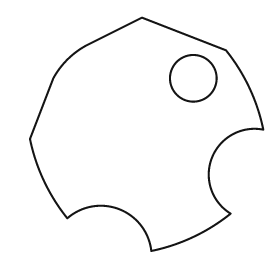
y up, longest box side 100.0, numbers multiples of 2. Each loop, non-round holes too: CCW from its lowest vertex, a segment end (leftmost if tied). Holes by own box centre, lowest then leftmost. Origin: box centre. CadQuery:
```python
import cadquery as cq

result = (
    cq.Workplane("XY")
    .moveTo(2.0, -50.0)
    .threePointArc((20.0, -44.0), (36.0, -34.0))
    .threePointArc((28.0, -10.0), (50.0, 2.0))
    .threePointArc((44.0, 20.0), (34.0, 36.0))
    .lineTo(-2.0, 50.0)
    .lineTo(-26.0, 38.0)
    .threePointArc((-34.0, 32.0), (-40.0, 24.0))
    .lineTo(-50.0, -2.0)
    .threePointArc((-44.0, -20.0), (-34.0, -36.0))
    .threePointArc((-12.0, -32.0), (2.0, -50.0))
    .close()
    .moveTo(20.0, 24.0)
    .circle(10.0)
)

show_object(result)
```